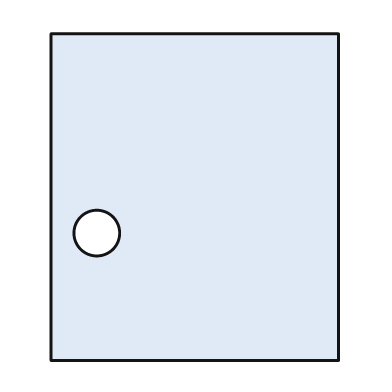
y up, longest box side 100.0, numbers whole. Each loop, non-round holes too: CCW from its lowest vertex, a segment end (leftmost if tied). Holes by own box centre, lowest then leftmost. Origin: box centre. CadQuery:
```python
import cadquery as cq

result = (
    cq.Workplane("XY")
    .moveTo(-44.0, -50.0)
    .lineTo(44.0, -50.0)
    .lineTo(44.0, 50.0)
    .lineTo(-44.0, 50.0)
    .close()
    .moveTo(-30.0, -11.0)
    .circle(7.0)
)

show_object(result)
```